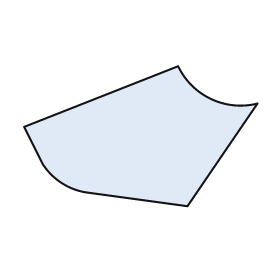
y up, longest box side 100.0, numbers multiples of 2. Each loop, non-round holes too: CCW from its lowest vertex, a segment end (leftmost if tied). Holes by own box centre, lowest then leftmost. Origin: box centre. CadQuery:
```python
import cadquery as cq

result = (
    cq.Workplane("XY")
    .moveTo(20.0, -30.0)
    .lineTo(50.0, 14.0)
    .threePointArc((30.0, 16.0), (16.0, 30.0))
    .lineTo(-50.0, 4.0)
    .lineTo(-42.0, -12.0)
    .threePointArc((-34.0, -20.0), (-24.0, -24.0))
    .close()
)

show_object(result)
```